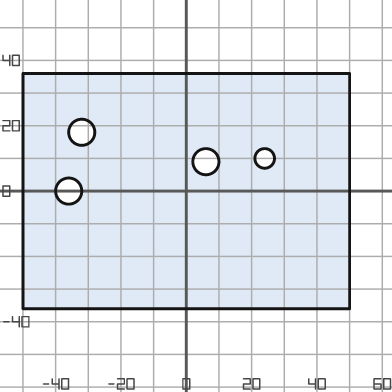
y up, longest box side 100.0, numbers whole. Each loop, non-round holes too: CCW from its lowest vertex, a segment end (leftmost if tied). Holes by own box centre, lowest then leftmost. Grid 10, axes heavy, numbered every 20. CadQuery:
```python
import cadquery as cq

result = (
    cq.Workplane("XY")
    .moveTo(-50.0, -36.0)
    .lineTo(50.0, -36.0)
    .lineTo(50.0, 36.0)
    .lineTo(-50.0, 36.0)
    .close()
    .moveTo(-36.0, 0.0)
    .circle(4.0)
    .moveTo(6.0, 9.0)
    .circle(4.0)
    .moveTo(24.0, 10.0)
    .circle(3.0)
    .moveTo(-32.0, 18.0)
    .circle(4.0)
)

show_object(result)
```